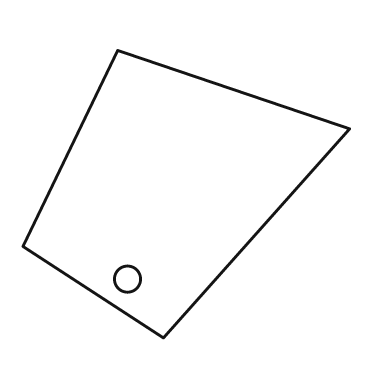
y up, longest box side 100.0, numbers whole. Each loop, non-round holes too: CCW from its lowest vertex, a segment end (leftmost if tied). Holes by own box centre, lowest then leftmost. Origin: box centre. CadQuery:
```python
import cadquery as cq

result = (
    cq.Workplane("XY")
    .moveTo(-7.0, -44.0)
    .lineTo(50.0, 20.0)
    .lineTo(-21.0, 44.0)
    .lineTo(-50.0, -16.0)
    .close()
    .moveTo(-18.0, -26.0)
    .circle(4.0)
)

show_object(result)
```